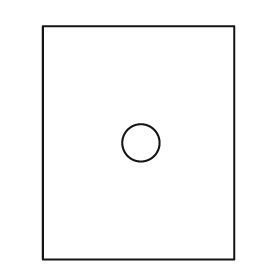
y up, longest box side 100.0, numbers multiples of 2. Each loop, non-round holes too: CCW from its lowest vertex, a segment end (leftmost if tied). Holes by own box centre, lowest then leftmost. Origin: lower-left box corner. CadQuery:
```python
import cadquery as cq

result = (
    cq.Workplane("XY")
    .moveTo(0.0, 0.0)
    .lineTo(82.0, 0.0)
    .lineTo(82.0, 100.0)
    .lineTo(0.0, 100.0)
    .close()
    .moveTo(42.0, 50.0)
    .circle(8.0)
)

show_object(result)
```